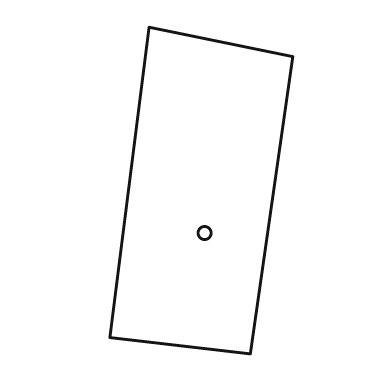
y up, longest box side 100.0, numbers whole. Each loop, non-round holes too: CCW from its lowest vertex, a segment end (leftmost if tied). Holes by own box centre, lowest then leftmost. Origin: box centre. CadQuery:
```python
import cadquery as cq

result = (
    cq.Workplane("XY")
    .moveTo(15.0, -50.0)
    .lineTo(28.0, 41.0)
    .lineTo(-16.0, 50.0)
    .lineTo(-28.0, -45.0)
    .close()
    .moveTo(1.0, -13.0)
    .circle(2.0)
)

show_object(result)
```